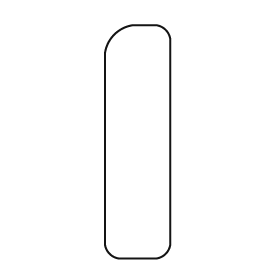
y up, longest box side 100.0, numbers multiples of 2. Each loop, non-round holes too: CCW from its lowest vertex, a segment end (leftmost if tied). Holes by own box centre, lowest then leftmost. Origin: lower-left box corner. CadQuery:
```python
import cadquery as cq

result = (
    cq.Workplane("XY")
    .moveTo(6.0, 0.0)
    .lineTo(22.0, 0.0)
    .threePointArc((26.0, 2.0), (28.0, 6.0))
    .lineTo(28.0, 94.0)
    .threePointArc((26.0, 98.0), (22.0, 100.0))
    .lineTo(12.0, 100.0)
    .threePointArc((4.0, 96.0), (0.0, 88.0))
    .lineTo(0.0, 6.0)
    .threePointArc((2.0, 2.0), (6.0, 0.0))
    .close()
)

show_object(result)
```